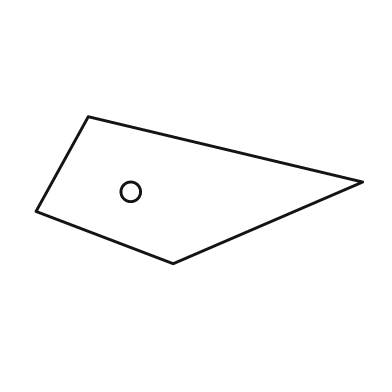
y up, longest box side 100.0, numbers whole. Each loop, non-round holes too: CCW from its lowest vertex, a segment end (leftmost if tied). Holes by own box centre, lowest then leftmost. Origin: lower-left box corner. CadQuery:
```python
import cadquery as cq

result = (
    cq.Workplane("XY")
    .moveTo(42.0, 0.0)
    .lineTo(100.0, 25.0)
    .lineTo(16.0, 45.0)
    .lineTo(0.0, 16.0)
    .close()
    .moveTo(29.0, 22.0)
    .circle(3.0)
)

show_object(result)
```